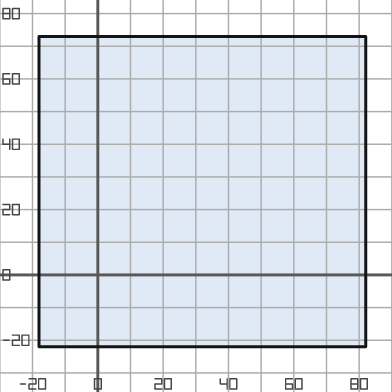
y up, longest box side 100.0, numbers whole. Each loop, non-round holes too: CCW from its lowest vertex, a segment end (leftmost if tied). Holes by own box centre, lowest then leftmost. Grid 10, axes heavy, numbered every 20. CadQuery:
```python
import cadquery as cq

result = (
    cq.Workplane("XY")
    .moveTo(-18.0, -22.0)
    .lineTo(82.0, -22.0)
    .lineTo(82.0, 73.0)
    .lineTo(-18.0, 73.0)
    .close()
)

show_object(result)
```